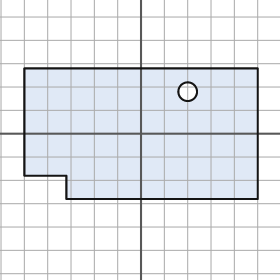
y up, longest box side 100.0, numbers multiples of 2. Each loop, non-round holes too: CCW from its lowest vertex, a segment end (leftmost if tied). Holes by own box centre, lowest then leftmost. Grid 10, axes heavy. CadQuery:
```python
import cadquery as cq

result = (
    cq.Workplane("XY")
    .moveTo(-32.0, -28.0)
    .lineTo(50.0, -28.0)
    .lineTo(50.0, 28.0)
    .lineTo(-50.0, 28.0)
    .lineTo(-50.0, -18.0)
    .lineTo(-32.0, -18.0)
    .close()
    .moveTo(20.0, 18.0)
    .circle(4.0)
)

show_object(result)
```